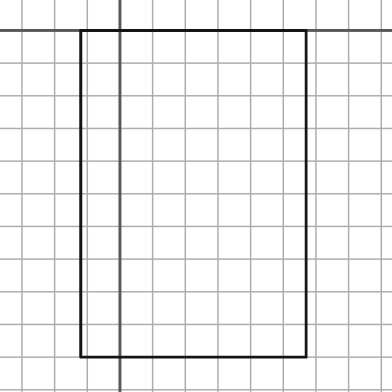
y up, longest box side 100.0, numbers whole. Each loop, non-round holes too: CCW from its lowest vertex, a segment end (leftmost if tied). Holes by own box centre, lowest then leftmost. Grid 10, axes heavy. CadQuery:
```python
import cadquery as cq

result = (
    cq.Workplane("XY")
    .moveTo(-12.0, -100.0)
    .lineTo(57.0, -100.0)
    .lineTo(57.0, 0.0)
    .lineTo(-12.0, 0.0)
    .close()
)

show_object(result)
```